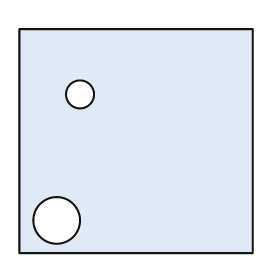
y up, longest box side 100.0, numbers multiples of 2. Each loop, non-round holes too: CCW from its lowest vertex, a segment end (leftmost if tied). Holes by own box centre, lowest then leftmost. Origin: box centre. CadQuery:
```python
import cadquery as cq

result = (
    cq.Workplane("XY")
    .moveTo(-50.0, -48.0)
    .lineTo(50.0, -48.0)
    .lineTo(50.0, 48.0)
    .lineTo(-50.0, 48.0)
    .close()
    .moveTo(-34.0, -34.0)
    .circle(10.0)
    .moveTo(-24.0, 20.0)
    .circle(6.0)
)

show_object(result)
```